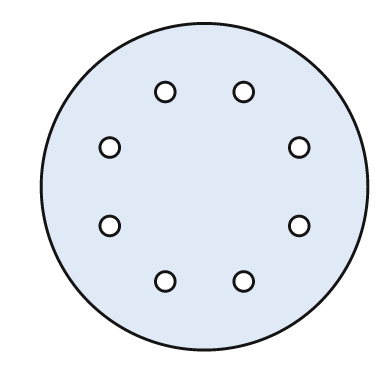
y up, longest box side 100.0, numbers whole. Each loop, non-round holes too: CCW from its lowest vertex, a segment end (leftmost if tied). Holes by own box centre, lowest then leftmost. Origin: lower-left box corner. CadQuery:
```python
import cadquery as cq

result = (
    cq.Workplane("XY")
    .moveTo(50.0, 50.0)
    .circle(50.0)
    .moveTo(38.0, 21.0)
    .circle(3.0)
    .moveTo(62.0, 21.0)
    .circle(3.0)
    .moveTo(21.0, 38.0)
    .circle(3.0)
    .moveTo(79.0, 38.0)
    .circle(3.0)
    .moveTo(21.0, 62.0)
    .circle(3.0)
    .moveTo(79.0, 62.0)
    .circle(3.0)
    .moveTo(38.0, 79.0)
    .circle(3.0)
    .moveTo(62.0, 79.0)
    .circle(3.0)
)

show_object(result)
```